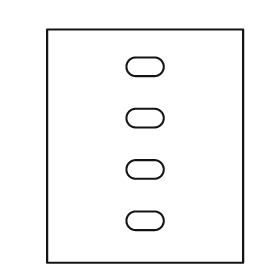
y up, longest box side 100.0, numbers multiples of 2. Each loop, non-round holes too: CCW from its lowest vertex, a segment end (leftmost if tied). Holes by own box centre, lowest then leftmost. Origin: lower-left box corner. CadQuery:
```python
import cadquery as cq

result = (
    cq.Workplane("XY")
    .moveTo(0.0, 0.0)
    .lineTo(84.0, 0.0)
    .lineTo(84.0, 100.0)
    .lineTo(0.0, 100.0)
    .close()
    .moveTo(38.0, 14.0)
    .lineTo(46.0, 14.0)
    .threePointArc((50.0, 18.0), (46.0, 22.0))
    .lineTo(38.0, 22.0)
    .threePointArc((34.0, 18.0), (38.0, 14.0))
    .close()
    .moveTo(38.0, 36.0)
    .lineTo(46.0, 36.0)
    .threePointArc((50.0, 40.0), (46.0, 44.0))
    .lineTo(38.0, 44.0)
    .threePointArc((34.0, 40.0), (38.0, 36.0))
    .close()
    .moveTo(38.0, 58.0)
    .lineTo(46.0, 58.0)
    .threePointArc((50.0, 62.0), (46.0, 66.0))
    .lineTo(38.0, 66.0)
    .threePointArc((34.0, 62.0), (38.0, 58.0))
    .close()
    .moveTo(38.0, 80.0)
    .lineTo(46.0, 80.0)
    .threePointArc((50.0, 84.0), (46.0, 88.0))
    .lineTo(38.0, 88.0)
    .threePointArc((34.0, 84.0), (38.0, 80.0))
    .close()
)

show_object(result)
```